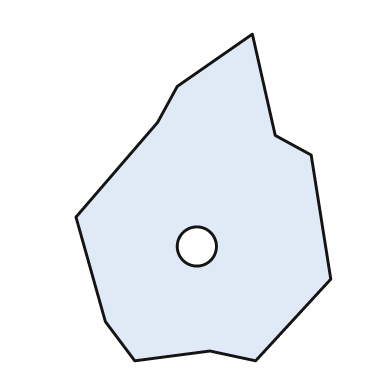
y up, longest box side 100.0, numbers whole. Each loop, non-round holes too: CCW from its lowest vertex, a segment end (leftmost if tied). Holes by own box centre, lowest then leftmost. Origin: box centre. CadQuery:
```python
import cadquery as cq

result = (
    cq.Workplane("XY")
    .moveTo(-21.0, -50.0)
    .lineTo(2.0, -47.0)
    .lineTo(16.0, -50.0)
    .lineTo(39.0, -25.0)
    .lineTo(33.0, 13.0)
    .lineTo(22.0, 19.0)
    .lineTo(15.0, 50.0)
    .lineTo(-8.0, 34.0)
    .lineTo(-14.0, 23.0)
    .lineTo(-39.0, -6.0)
    .lineTo(-30.0, -38.0)
    .close()
    .moveTo(-2.0, -15.0)
    .circle(6.0)
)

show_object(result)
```